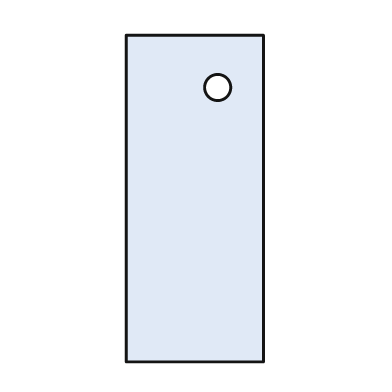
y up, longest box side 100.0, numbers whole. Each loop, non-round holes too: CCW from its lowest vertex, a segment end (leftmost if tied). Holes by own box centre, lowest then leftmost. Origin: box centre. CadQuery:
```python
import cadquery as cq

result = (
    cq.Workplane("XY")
    .moveTo(-21.0, -50.0)
    .lineTo(21.0, -50.0)
    .lineTo(21.0, 50.0)
    .lineTo(-21.0, 50.0)
    .close()
    .moveTo(7.0, 34.0)
    .circle(4.0)
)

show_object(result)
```